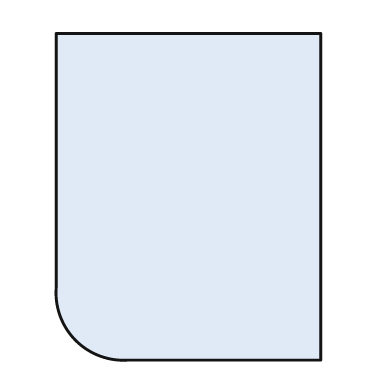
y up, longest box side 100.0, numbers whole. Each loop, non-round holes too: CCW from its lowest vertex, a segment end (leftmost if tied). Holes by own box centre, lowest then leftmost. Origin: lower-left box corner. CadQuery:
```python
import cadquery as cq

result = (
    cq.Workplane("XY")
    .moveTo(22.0, 0.0)
    .lineTo(81.0, 0.0)
    .lineTo(81.0, 100.0)
    .lineTo(0.0, 100.0)
    .lineTo(0.0, 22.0)
    .threePointArc((6.0, 6.0), (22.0, 0.0))
    .close()
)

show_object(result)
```